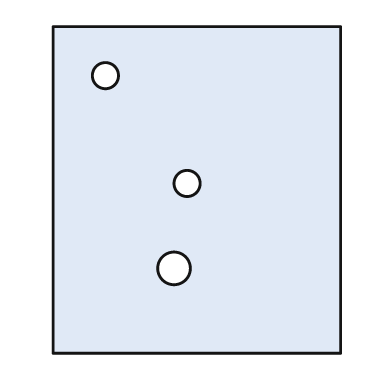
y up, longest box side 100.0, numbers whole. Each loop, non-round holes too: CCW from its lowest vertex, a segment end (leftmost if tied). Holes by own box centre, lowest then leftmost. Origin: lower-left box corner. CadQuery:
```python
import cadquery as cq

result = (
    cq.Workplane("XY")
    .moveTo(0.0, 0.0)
    .lineTo(88.0, 0.0)
    .lineTo(88.0, 100.0)
    .lineTo(0.0, 100.0)
    .close()
    .moveTo(37.0, 26.0)
    .circle(5.0)
    .moveTo(41.0, 52.0)
    .circle(4.0)
    .moveTo(16.0, 85.0)
    .circle(4.0)
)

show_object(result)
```